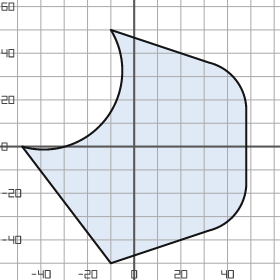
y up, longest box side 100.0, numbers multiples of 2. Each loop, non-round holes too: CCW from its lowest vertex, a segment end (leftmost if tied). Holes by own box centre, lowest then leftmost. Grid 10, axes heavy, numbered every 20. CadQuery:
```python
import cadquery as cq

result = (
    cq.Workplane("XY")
    .moveTo(-10.0, -50.0)
    .lineTo(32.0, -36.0)
    .threePointArc((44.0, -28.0), (48.0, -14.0))
    .lineTo(48.0, 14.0)
    .threePointArc((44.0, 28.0), (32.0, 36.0))
    .lineTo(-10.0, 50.0)
    .threePointArc((-12.0, 12.0), (-48.0, 0.0))
    .close()
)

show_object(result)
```